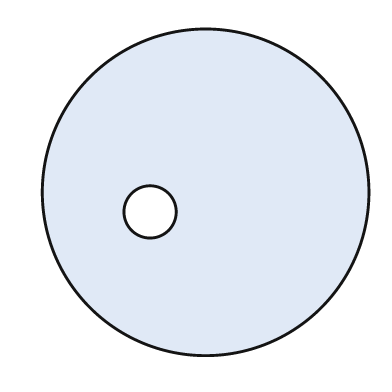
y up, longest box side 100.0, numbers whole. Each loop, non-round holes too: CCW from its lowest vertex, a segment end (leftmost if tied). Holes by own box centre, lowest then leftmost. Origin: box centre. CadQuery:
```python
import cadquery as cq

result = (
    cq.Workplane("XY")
    .moveTo(0.0, 0.0)
    .circle(50.0)
    .moveTo(-17.0, -6.0)
    .circle(8.0)
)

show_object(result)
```